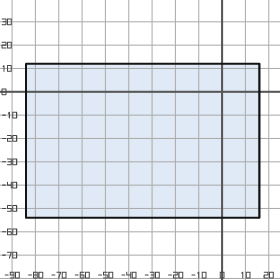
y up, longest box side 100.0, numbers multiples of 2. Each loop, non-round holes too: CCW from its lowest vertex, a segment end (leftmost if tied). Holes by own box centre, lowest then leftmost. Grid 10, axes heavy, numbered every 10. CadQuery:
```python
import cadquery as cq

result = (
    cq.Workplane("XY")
    .moveTo(-84.0, -54.0)
    .lineTo(16.0, -54.0)
    .lineTo(16.0, 12.0)
    .lineTo(-84.0, 12.0)
    .close()
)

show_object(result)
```